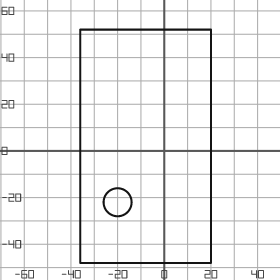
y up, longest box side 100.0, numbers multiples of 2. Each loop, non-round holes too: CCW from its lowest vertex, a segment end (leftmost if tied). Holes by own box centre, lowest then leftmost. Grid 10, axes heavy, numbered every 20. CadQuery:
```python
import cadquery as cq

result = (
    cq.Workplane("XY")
    .moveTo(-36.0, -48.0)
    .lineTo(20.0, -48.0)
    .lineTo(20.0, 52.0)
    .lineTo(-36.0, 52.0)
    .close()
    .moveTo(-20.0, -22.0)
    .circle(6.0)
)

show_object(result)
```